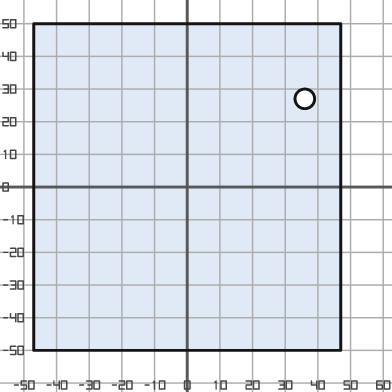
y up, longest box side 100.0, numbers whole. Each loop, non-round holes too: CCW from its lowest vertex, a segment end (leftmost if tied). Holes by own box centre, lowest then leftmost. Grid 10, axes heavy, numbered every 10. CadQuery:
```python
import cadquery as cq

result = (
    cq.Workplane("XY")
    .moveTo(-47.0, -50.0)
    .lineTo(47.0, -50.0)
    .lineTo(47.0, 50.0)
    .lineTo(-47.0, 50.0)
    .close()
    .moveTo(36.0, 27.0)
    .circle(3.0)
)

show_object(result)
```